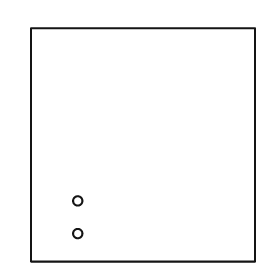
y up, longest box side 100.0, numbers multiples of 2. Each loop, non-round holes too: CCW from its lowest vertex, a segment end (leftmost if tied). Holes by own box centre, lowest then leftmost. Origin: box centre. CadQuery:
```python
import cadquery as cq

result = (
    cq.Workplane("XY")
    .moveTo(-48.0, -50.0)
    .lineTo(48.0, -50.0)
    .lineTo(48.0, 50.0)
    .lineTo(-48.0, 50.0)
    .close()
    .moveTo(-28.0, -38.0)
    .circle(2.0)
    .moveTo(-28.0, -24.0)
    .circle(2.0)
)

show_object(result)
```